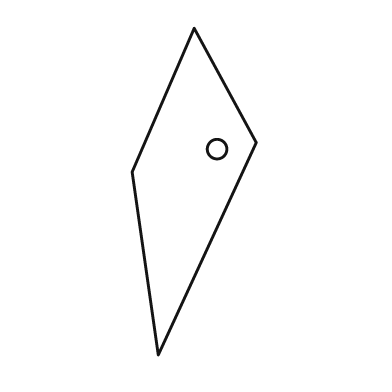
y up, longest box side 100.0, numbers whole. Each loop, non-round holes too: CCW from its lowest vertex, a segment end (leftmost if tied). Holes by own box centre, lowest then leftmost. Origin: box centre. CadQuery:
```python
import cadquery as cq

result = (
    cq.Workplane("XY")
    .moveTo(-11.0, -50.0)
    .lineTo(19.0, 15.0)
    .lineTo(0.0, 50.0)
    .lineTo(-19.0, 6.0)
    .close()
    .moveTo(7.0, 13.0)
    .circle(3.0)
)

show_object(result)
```